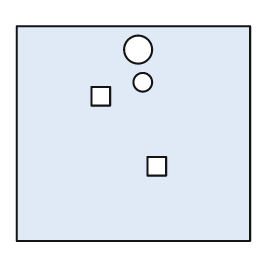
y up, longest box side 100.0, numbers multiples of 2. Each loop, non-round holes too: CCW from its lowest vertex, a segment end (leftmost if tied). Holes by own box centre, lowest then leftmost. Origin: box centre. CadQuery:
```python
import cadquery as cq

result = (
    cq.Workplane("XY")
    .moveTo(-50.0, -46.0)
    .lineTo(50.0, -46.0)
    .lineTo(50.0, 46.0)
    .lineTo(-50.0, 46.0)
    .close()
    .moveTo(6.0, -18.0)
    .lineTo(14.0, -18.0)
    .lineTo(14.0, -10.0)
    .lineTo(6.0, -10.0)
    .close()
    .moveTo(-18.0, 12.0)
    .lineTo(-10.0, 12.0)
    .lineTo(-10.0, 20.0)
    .lineTo(-18.0, 20.0)
    .close()
    .moveTo(4.0, 22.0)
    .circle(4.0)
    .moveTo(2.0, 36.0)
    .circle(6.0)
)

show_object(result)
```